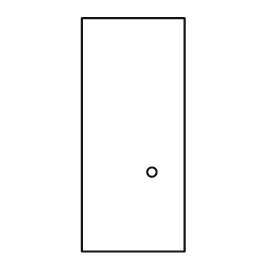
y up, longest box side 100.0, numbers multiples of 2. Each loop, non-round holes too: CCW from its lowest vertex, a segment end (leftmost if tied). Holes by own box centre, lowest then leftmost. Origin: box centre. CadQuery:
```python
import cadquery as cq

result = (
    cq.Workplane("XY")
    .moveTo(-22.0, -50.0)
    .lineTo(22.0, -50.0)
    .lineTo(22.0, 50.0)
    .lineTo(-22.0, 50.0)
    .close()
    .moveTo(8.0, -16.0)
    .circle(2.0)
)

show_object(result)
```